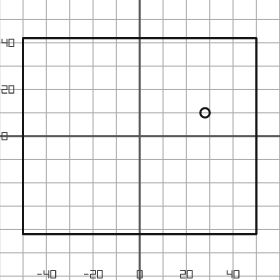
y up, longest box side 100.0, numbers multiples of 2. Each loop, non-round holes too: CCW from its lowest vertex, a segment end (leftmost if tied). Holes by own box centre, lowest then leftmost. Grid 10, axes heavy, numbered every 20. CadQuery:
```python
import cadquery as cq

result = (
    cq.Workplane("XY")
    .moveTo(-50.0, -42.0)
    .lineTo(50.0, -42.0)
    .lineTo(50.0, 42.0)
    .lineTo(-50.0, 42.0)
    .close()
    .moveTo(28.0, 10.0)
    .circle(2.0)
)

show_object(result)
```